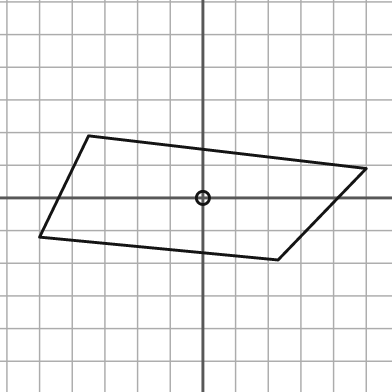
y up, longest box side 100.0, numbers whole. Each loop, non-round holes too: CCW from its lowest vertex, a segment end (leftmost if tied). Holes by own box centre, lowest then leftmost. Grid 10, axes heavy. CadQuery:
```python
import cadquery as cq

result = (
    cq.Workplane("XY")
    .moveTo(23.0, -19.0)
    .lineTo(50.0, 9.0)
    .lineTo(-35.0, 19.0)
    .lineTo(-50.0, -12.0)
    .close()
    .moveTo(0.0, 0.0)
    .circle(2.0)
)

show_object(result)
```